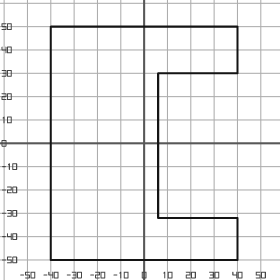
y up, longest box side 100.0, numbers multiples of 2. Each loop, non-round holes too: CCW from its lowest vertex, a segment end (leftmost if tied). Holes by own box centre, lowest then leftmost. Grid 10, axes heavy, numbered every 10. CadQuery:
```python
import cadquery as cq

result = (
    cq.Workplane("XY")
    .moveTo(-40.0, -50.0)
    .lineTo(40.0, -50.0)
    .lineTo(40.0, -32.0)
    .lineTo(6.0, -32.0)
    .lineTo(6.0, 30.0)
    .lineTo(40.0, 30.0)
    .lineTo(40.0, 50.0)
    .lineTo(-40.0, 50.0)
    .close()
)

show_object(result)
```